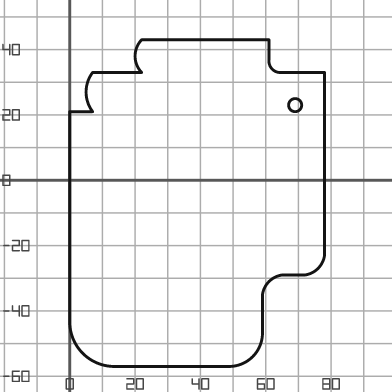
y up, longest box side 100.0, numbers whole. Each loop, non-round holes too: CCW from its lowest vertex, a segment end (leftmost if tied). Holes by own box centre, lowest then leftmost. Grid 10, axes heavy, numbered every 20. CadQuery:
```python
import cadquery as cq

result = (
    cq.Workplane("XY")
    .moveTo(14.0, -57.0)
    .lineTo(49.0, -57.0)
    .threePointArc((56.0, -54.0), (59.0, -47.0))
    .lineTo(59.0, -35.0)
    .threePointArc((61.0, -31.0), (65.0, -29.0))
    .lineTo(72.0, -29.0)
    .threePointArc((76.0, -27.0), (78.0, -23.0))
    .lineTo(78.0, 33.0)
    .lineTo(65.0, 33.0)
    .threePointArc((62.0, 34.0), (61.0, 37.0))
    .lineTo(61.0, 43.0)
    .lineTo(22.0, 43.0)
    .threePointArc((20.0, 38.0), (22.0, 33.0))
    .lineTo(7.0, 33.0)
    .threePointArc((5.0, 27.0), (7.0, 21.0))
    .lineTo(0.0, 21.0)
    .lineTo(0.0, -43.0)
    .threePointArc((4.0, -53.0), (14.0, -57.0))
    .close()
    .moveTo(69.0, 23.0)
    .circle(2.0)
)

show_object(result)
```